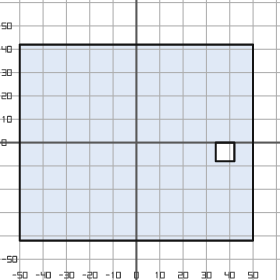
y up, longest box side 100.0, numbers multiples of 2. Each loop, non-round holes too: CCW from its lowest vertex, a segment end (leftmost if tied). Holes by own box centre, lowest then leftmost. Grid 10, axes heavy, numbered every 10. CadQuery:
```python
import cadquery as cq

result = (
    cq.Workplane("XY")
    .moveTo(-50.0, -42.0)
    .lineTo(50.0, -42.0)
    .lineTo(50.0, 42.0)
    .lineTo(-50.0, 42.0)
    .close()
    .moveTo(34.0, -8.0)
    .lineTo(42.0, -8.0)
    .lineTo(42.0, 0.0)
    .lineTo(34.0, 0.0)
    .close()
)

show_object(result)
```